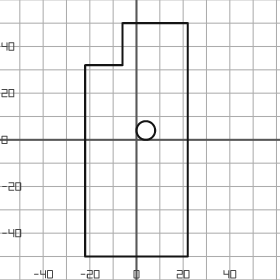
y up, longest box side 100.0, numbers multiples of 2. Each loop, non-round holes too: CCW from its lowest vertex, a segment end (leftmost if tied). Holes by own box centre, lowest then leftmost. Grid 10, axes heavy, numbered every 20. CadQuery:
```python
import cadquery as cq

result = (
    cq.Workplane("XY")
    .moveTo(-22.0, -50.0)
    .lineTo(22.0, -50.0)
    .lineTo(22.0, 50.0)
    .lineTo(-6.0, 50.0)
    .lineTo(-6.0, 32.0)
    .lineTo(-22.0, 32.0)
    .close()
    .moveTo(4.0, 4.0)
    .circle(4.0)
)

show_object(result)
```